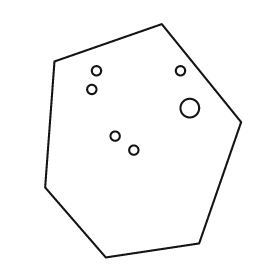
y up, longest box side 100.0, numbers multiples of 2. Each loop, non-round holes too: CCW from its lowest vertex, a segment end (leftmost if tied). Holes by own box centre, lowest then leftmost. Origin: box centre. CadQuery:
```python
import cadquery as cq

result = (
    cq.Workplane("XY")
    .moveTo(-16.0, -50.0)
    .lineTo(24.0, -44.0)
    .lineTo(42.0, 8.0)
    .lineTo(8.0, 50.0)
    .lineTo(-38.0, 34.0)
    .lineTo(-42.0, -20.0)
    .close()
    .moveTo(-4.0, -4.0)
    .circle(2.0)
    .moveTo(-12.0, 2.0)
    .circle(2.0)
    .moveTo(20.0, 14.0)
    .circle(4.0)
    .moveTo(-22.0, 22.0)
    .circle(2.0)
    .moveTo(-20.0, 30.0)
    .circle(2.0)
    .moveTo(16.0, 30.0)
    .circle(2.0)
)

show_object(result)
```